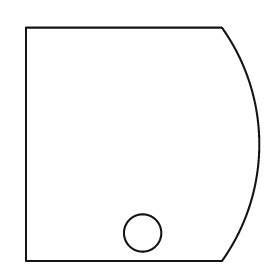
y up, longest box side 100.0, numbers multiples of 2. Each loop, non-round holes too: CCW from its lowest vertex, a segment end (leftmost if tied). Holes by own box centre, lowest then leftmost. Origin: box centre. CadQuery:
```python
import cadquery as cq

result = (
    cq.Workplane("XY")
    .moveTo(-50.0, -50.0)
    .lineTo(34.0, -50.0)
    .threePointArc((50.0, 0.0), (34.0, 50.0))
    .lineTo(-50.0, 50.0)
    .close()
    .moveTo(0.0, -38.0)
    .circle(8.0)
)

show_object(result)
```